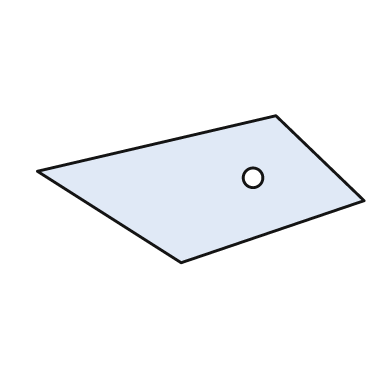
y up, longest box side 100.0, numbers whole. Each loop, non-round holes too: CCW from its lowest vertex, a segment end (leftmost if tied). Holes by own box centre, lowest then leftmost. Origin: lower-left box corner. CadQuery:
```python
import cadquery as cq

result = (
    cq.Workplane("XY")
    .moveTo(44.0, 0.0)
    .lineTo(100.0, 19.0)
    .lineTo(73.0, 45.0)
    .lineTo(0.0, 28.0)
    .close()
    .moveTo(66.0, 26.0)
    .circle(3.0)
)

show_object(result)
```